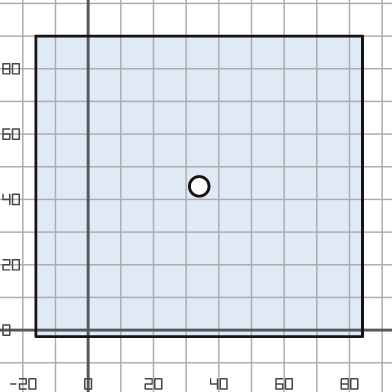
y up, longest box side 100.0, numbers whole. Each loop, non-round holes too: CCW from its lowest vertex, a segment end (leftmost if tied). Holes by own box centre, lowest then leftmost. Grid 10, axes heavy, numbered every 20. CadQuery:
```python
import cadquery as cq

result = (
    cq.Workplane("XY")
    .moveTo(-16.0, -2.0)
    .lineTo(84.0, -2.0)
    .lineTo(84.0, 90.0)
    .lineTo(-16.0, 90.0)
    .close()
    .moveTo(34.0, 44.0)
    .circle(3.0)
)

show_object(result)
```